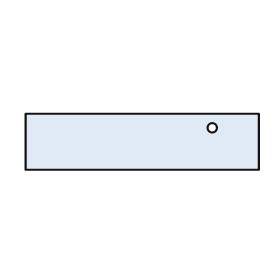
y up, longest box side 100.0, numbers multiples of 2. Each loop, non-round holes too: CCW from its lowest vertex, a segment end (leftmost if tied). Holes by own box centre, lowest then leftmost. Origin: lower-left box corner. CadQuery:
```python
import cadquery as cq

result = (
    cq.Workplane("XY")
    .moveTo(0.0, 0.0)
    .lineTo(100.0, 0.0)
    .lineTo(100.0, 24.0)
    .lineTo(0.0, 24.0)
    .close()
    .moveTo(80.0, 18.0)
    .circle(2.0)
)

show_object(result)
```